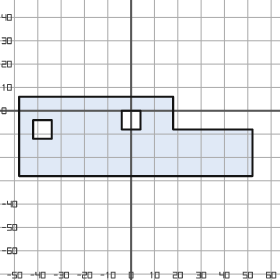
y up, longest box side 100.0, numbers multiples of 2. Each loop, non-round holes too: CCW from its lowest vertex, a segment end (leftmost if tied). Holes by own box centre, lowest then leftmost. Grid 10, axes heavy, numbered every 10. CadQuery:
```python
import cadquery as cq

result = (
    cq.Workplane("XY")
    .moveTo(-48.0, -28.0)
    .lineTo(52.0, -28.0)
    .lineTo(52.0, -8.0)
    .lineTo(18.0, -8.0)
    .lineTo(18.0, 6.0)
    .lineTo(-48.0, 6.0)
    .close()
    .moveTo(-42.0, -12.0)
    .lineTo(-34.0, -12.0)
    .lineTo(-34.0, -4.0)
    .lineTo(-42.0, -4.0)
    .close()
    .moveTo(-4.0, -8.0)
    .lineTo(4.0, -8.0)
    .lineTo(4.0, 0.0)
    .lineTo(-4.0, 0.0)
    .close()
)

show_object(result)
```